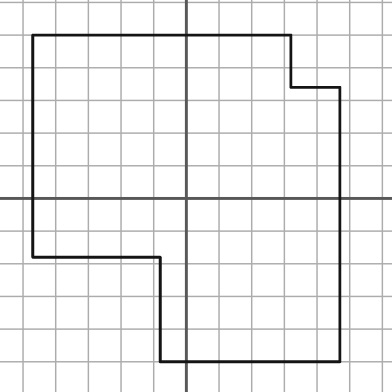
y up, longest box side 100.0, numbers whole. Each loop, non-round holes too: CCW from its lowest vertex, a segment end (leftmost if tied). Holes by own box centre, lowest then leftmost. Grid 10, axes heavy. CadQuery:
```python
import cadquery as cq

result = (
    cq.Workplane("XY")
    .moveTo(-8.0, -50.0)
    .lineTo(47.0, -50.0)
    .lineTo(47.0, 34.0)
    .lineTo(32.0, 34.0)
    .lineTo(32.0, 50.0)
    .lineTo(-47.0, 50.0)
    .lineTo(-47.0, -18.0)
    .lineTo(-8.0, -18.0)
    .close()
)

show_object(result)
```